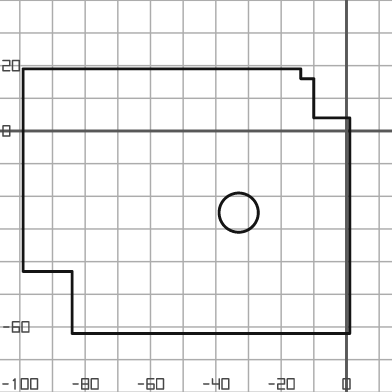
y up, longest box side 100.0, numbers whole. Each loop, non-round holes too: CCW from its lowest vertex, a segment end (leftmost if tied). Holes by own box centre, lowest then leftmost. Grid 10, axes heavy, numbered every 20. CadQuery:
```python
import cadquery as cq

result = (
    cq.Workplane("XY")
    .moveTo(-84.0, -62.0)
    .lineTo(1.0, -62.0)
    .lineTo(1.0, 4.0)
    .lineTo(-10.0, 4.0)
    .lineTo(-10.0, 16.0)
    .lineTo(-14.0, 16.0)
    .lineTo(-14.0, 19.0)
    .lineTo(-99.0, 19.0)
    .lineTo(-99.0, -43.0)
    .lineTo(-84.0, -43.0)
    .close()
    .moveTo(-33.0, -25.0)
    .circle(6.0)
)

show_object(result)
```